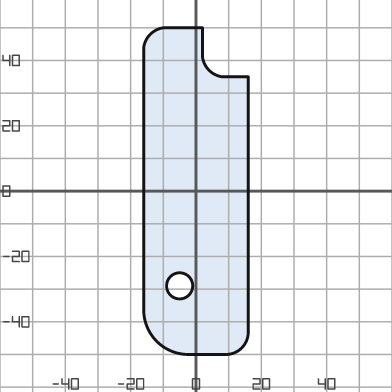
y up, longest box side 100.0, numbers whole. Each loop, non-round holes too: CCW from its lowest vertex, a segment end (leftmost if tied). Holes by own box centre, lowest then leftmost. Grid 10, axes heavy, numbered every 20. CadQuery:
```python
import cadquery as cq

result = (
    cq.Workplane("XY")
    .moveTo(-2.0, -50.0)
    .lineTo(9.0, -50.0)
    .threePointArc((14.0, -48.0), (16.0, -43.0))
    .lineTo(16.0, 35.0)
    .lineTo(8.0, 35.0)
    .threePointArc((4.0, 37.0), (2.0, 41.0))
    .lineTo(2.0, 50.0)
    .lineTo(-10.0, 50.0)
    .threePointArc((-14.0, 48.0), (-16.0, 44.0))
    .lineTo(-16.0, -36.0)
    .threePointArc((-12.0, -46.0), (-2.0, -50.0))
    .close()
    .moveTo(-5.0, -29.0)
    .circle(4.0)
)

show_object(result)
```